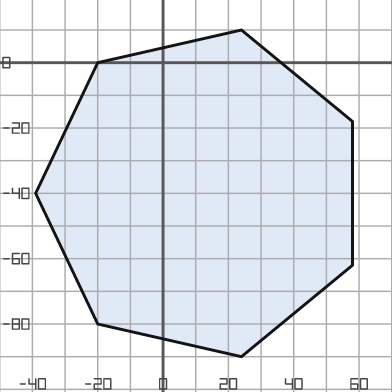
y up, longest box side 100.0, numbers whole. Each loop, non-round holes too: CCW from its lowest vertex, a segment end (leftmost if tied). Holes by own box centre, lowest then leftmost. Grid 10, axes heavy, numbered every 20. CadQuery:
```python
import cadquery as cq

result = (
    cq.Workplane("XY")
    .moveTo(24.0, -90.0)
    .lineTo(58.0, -62.0)
    .lineTo(58.0, -18.0)
    .lineTo(24.0, 10.0)
    .lineTo(-20.0, 0.0)
    .lineTo(-39.0, -40.0)
    .lineTo(-20.0, -80.0)
    .close()
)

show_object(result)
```